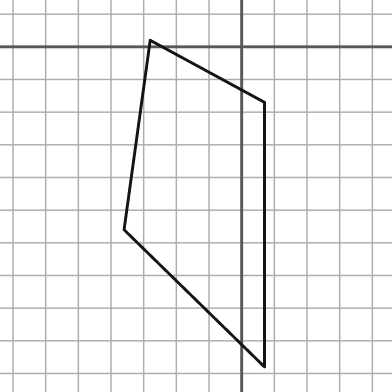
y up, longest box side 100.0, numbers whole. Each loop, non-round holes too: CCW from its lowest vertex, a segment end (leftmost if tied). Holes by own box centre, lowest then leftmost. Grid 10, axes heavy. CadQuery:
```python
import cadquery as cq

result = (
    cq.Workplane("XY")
    .moveTo(7.0, -98.0)
    .lineTo(7.0, -17.0)
    .lineTo(-28.0, 2.0)
    .lineTo(-36.0, -56.0)
    .close()
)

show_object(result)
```